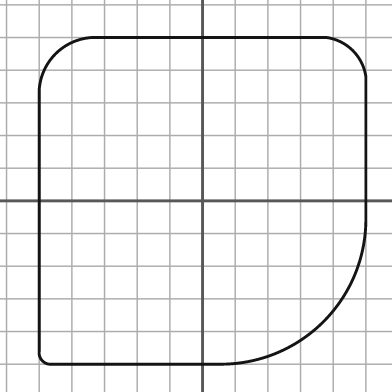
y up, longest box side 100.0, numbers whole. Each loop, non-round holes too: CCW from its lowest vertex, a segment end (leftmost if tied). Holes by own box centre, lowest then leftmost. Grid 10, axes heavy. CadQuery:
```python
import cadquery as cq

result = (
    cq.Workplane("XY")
    .moveTo(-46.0, -50.0)
    .lineTo(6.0, -50.0)
    .threePointArc((37.0, -37.0), (50.0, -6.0))
    .lineTo(50.0, 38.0)
    .threePointArc((46.0, 46.0), (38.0, 50.0))
    .lineTo(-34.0, 50.0)
    .threePointArc((-45.0, 45.0), (-50.0, 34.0))
    .lineTo(-50.0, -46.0)
    .threePointArc((-49.0, -49.0), (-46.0, -50.0))
    .close()
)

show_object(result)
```